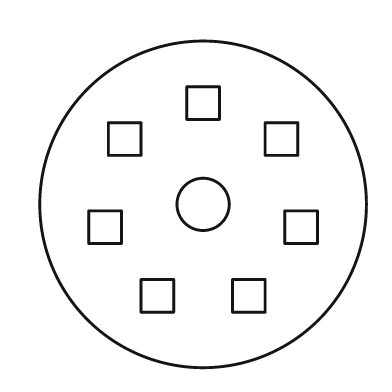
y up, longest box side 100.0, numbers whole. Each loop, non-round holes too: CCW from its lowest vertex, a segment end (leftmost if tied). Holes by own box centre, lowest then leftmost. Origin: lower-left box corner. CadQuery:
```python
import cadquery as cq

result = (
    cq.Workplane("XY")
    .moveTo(50.0, 50.0)
    .circle(50.0)
    .moveTo(31.0, 17.0)
    .lineTo(41.0, 17.0)
    .lineTo(41.0, 27.0)
    .lineTo(31.0, 27.0)
    .close()
    .moveTo(59.0, 17.0)
    .lineTo(69.0, 17.0)
    .lineTo(69.0, 27.0)
    .lineTo(59.0, 27.0)
    .close()
    .moveTo(15.0, 38.0)
    .lineTo(25.0, 38.0)
    .lineTo(25.0, 48.0)
    .lineTo(15.0, 48.0)
    .close()
    .moveTo(75.0, 38.0)
    .lineTo(85.0, 38.0)
    .lineTo(85.0, 48.0)
    .lineTo(75.0, 48.0)
    .close()
    .moveTo(50.0, 50.0)
    .circle(8.0)
    .moveTo(21.0, 65.0)
    .lineTo(31.0, 65.0)
    .lineTo(31.0, 75.0)
    .lineTo(21.0, 75.0)
    .close()
    .moveTo(69.0, 65.0)
    .lineTo(79.0, 65.0)
    .lineTo(79.0, 75.0)
    .lineTo(69.0, 75.0)
    .close()
    .moveTo(45.0, 76.0)
    .lineTo(55.0, 76.0)
    .lineTo(55.0, 86.0)
    .lineTo(45.0, 86.0)
    .close()
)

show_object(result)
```